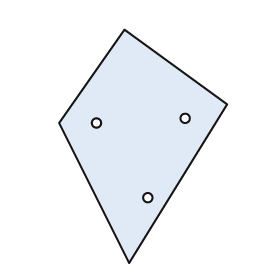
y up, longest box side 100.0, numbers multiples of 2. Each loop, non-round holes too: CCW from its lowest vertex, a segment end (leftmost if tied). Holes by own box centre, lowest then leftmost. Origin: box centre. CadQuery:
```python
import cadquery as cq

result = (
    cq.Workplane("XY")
    .moveTo(-6.0, -50.0)
    .lineTo(36.0, 18.0)
    .lineTo(-8.0, 50.0)
    .lineTo(-36.0, 10.0)
    .close()
    .moveTo(2.0, -22.0)
    .circle(2.0)
    .moveTo(-20.0, 10.0)
    .circle(2.0)
    .moveTo(18.0, 12.0)
    .circle(2.0)
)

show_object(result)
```